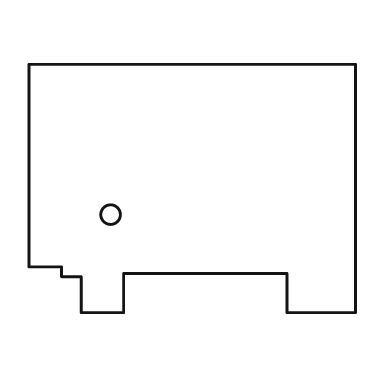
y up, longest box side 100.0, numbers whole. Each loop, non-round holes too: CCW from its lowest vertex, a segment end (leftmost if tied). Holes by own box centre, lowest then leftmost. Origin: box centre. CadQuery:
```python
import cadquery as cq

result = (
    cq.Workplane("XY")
    .moveTo(-34.0, -38.0)
    .lineTo(-21.0, -38.0)
    .lineTo(-21.0, -26.0)
    .lineTo(29.0, -26.0)
    .lineTo(29.0, -38.0)
    .lineTo(50.0, -38.0)
    .lineTo(50.0, 38.0)
    .lineTo(-50.0, 38.0)
    .lineTo(-50.0, -24.0)
    .lineTo(-40.0, -24.0)
    .lineTo(-40.0, -27.0)
    .lineTo(-34.0, -27.0)
    .close()
    .moveTo(-25.0, -8.0)
    .circle(3.0)
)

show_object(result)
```